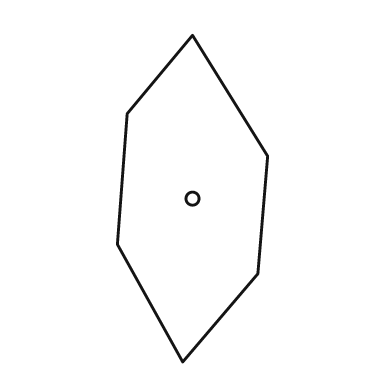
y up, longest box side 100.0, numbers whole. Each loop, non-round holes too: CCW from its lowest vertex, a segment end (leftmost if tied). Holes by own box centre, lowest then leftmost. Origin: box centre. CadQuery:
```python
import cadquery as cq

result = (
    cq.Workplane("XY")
    .moveTo(-3.0, -50.0)
    .lineTo(20.0, -23.0)
    .lineTo(23.0, 13.0)
    .lineTo(0.0, 50.0)
    .lineTo(-20.0, 26.0)
    .lineTo(-23.0, -14.0)
    .close()
    .moveTo(0.0, 0.0)
    .circle(2.0)
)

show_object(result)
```